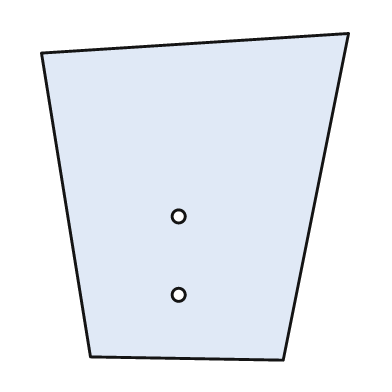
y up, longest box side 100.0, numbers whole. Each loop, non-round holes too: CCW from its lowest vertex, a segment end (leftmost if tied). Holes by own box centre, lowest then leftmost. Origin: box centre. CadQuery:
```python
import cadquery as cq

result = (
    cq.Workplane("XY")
    .moveTo(27.0, -50.0)
    .lineTo(47.0, 50.0)
    .lineTo(-47.0, 44.0)
    .lineTo(-32.0, -49.0)
    .close()
    .moveTo(-5.0, -30.0)
    .circle(2.0)
    .moveTo(-5.0, -6.0)
    .circle(2.0)
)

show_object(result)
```